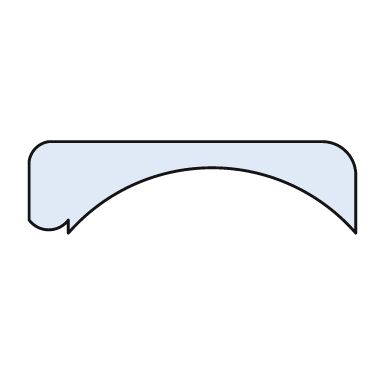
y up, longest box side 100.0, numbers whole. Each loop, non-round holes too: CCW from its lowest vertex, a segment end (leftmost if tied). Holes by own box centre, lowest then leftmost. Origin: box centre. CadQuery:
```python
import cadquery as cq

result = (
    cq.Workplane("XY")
    .moveTo(-38.0, -14.0)
    .threePointArc((6.0, 6.0), (50.0, -14.0))
    .lineTo(50.0, 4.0)
    .threePointArc((47.0, 11.0), (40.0, 14.0))
    .lineTo(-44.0, 14.0)
    .threePointArc((-48.0, 12.0), (-50.0, 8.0))
    .lineTo(-50.0, -10.0)
    .threePointArc((-44.0, -13.0), (-38.0, -10.0))
    .close()
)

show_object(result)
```